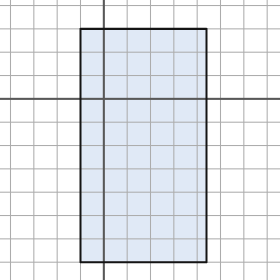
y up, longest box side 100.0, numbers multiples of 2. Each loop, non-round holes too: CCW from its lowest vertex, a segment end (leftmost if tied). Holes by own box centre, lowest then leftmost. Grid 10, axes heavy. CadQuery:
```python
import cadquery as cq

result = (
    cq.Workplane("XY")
    .moveTo(-10.0, -70.0)
    .lineTo(44.0, -70.0)
    .lineTo(44.0, 30.0)
    .lineTo(-10.0, 30.0)
    .close()
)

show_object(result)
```